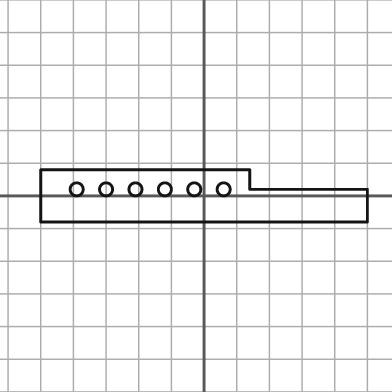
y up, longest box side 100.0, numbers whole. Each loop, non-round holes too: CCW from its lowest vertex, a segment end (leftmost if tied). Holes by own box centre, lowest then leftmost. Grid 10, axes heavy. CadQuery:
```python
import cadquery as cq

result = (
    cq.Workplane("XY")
    .moveTo(-50.0, -8.0)
    .lineTo(50.0, -8.0)
    .lineTo(50.0, 2.0)
    .lineTo(14.0, 2.0)
    .lineTo(14.0, 8.0)
    .lineTo(-50.0, 8.0)
    .close()
    .moveTo(-39.0, 2.0)
    .circle(2.0)
    .moveTo(-30.0, 2.0)
    .circle(2.0)
    .moveTo(-21.0, 2.0)
    .circle(2.0)
    .moveTo(-12.0, 2.0)
    .circle(2.0)
    .moveTo(-3.0, 2.0)
    .circle(2.0)
    .moveTo(6.0, 2.0)
    .circle(2.0)
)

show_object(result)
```